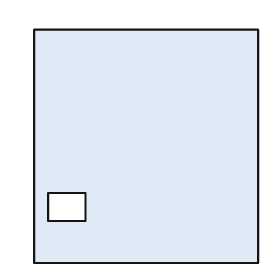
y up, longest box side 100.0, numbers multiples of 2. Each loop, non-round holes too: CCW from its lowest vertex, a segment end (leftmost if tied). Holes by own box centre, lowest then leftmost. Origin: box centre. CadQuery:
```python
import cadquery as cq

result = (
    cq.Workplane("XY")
    .moveTo(-48.0, -50.0)
    .lineTo(48.0, -50.0)
    .lineTo(48.0, 50.0)
    .lineTo(-48.0, 50.0)
    .close()
    .moveTo(-42.0, -32.0)
    .lineTo(-26.0, -32.0)
    .lineTo(-26.0, -20.0)
    .lineTo(-42.0, -20.0)
    .close()
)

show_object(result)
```